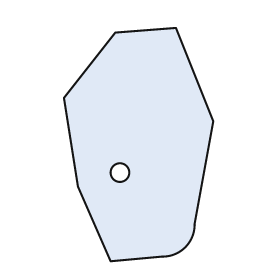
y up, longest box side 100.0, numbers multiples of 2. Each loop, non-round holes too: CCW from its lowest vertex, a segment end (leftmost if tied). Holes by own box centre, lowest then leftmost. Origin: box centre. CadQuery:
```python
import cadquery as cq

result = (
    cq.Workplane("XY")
    .moveTo(-12.0, -50.0)
    .lineTo(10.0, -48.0)
    .threePointArc((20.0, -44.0), (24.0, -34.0))
    .lineTo(32.0, 10.0)
    .lineTo(16.0, 50.0)
    .lineTo(-10.0, 48.0)
    .lineTo(-32.0, 20.0)
    .lineTo(-26.0, -18.0)
    .close()
    .moveTo(-8.0, -12.0)
    .circle(4.0)
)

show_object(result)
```